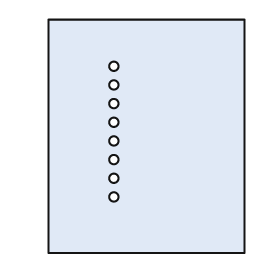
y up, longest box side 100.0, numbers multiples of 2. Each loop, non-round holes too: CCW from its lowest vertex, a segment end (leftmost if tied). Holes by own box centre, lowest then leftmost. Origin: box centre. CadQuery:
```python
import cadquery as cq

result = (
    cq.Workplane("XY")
    .moveTo(-42.0, -50.0)
    .lineTo(42.0, -50.0)
    .lineTo(42.0, 50.0)
    .lineTo(-42.0, 50.0)
    .close()
    .moveTo(-14.0, -26.0)
    .circle(2.0)
    .moveTo(-14.0, -18.0)
    .circle(2.0)
    .moveTo(-14.0, -10.0)
    .circle(2.0)
    .moveTo(-14.0, -2.0)
    .circle(2.0)
    .moveTo(-14.0, 6.0)
    .circle(2.0)
    .moveTo(-14.0, 14.0)
    .circle(2.0)
    .moveTo(-14.0, 22.0)
    .circle(2.0)
    .moveTo(-14.0, 30.0)
    .circle(2.0)
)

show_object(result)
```